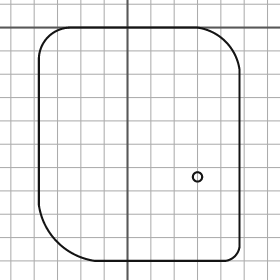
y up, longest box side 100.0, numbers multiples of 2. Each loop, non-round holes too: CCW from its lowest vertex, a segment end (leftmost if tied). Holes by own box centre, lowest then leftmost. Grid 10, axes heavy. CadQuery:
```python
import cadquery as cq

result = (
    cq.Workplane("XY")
    .moveTo(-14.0, -100.0)
    .lineTo(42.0, -100.0)
    .threePointArc((46.0, -98.0), (48.0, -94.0))
    .lineTo(48.0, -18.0)
    .threePointArc((42.0, -6.0), (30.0, 0.0))
    .lineTo(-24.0, 0.0)
    .threePointArc((-34.0, -4.0), (-38.0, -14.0))
    .lineTo(-38.0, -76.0)
    .threePointArc((-30.0, -92.0), (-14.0, -100.0))
    .close()
    .moveTo(30.0, -64.0)
    .circle(2.0)
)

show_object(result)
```